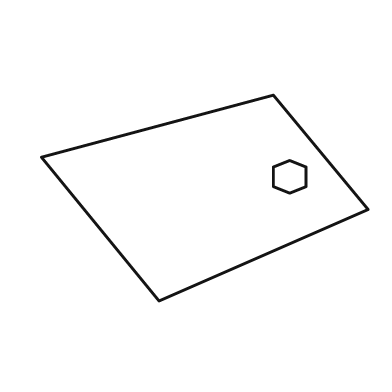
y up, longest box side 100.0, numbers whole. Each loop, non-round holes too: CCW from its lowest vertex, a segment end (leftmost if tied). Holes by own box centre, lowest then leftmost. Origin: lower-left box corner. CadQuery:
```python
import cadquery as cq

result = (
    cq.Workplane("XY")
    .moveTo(36.0, 0.0)
    .lineTo(100.0, 28.0)
    .lineTo(71.0, 63.0)
    .lineTo(0.0, 44.0)
    .close()
    .moveTo(76.0, 33.0)
    .lineTo(81.0, 35.0)
    .lineTo(81.0, 41.0)
    .lineTo(76.0, 43.0)
    .lineTo(71.0, 41.0)
    .lineTo(71.0, 35.0)
    .close()
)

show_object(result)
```